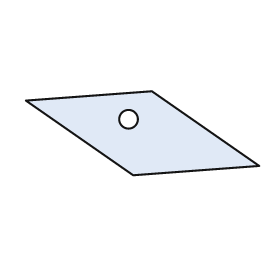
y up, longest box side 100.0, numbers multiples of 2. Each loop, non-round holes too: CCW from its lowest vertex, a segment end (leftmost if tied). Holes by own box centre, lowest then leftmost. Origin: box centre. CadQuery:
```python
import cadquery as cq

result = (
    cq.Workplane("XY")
    .moveTo(-4.0, -18.0)
    .lineTo(50.0, -14.0)
    .lineTo(4.0, 18.0)
    .lineTo(-50.0, 14.0)
    .close()
    .moveTo(-6.0, 6.0)
    .circle(4.0)
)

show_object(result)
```